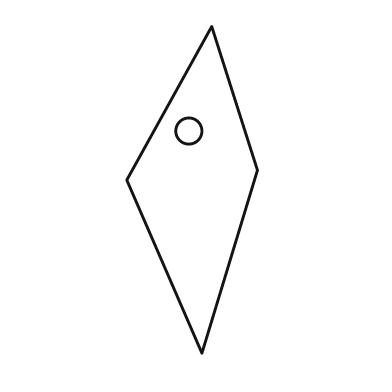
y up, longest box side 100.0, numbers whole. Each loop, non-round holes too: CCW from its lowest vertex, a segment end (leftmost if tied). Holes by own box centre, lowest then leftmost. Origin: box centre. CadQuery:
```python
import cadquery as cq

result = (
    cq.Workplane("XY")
    .moveTo(3.0, -50.0)
    .lineTo(20.0, 6.0)
    .lineTo(6.0, 50.0)
    .lineTo(-20.0, 3.0)
    .close()
    .moveTo(-1.0, 18.0)
    .circle(4.0)
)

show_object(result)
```